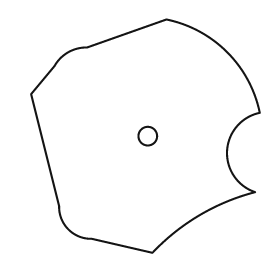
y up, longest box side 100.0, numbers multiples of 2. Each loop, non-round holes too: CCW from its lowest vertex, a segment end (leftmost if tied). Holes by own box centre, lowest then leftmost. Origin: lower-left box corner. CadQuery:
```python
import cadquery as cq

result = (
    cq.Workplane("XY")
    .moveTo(52.0, 0.0)
    .threePointArc((72.0, 16.0), (96.0, 26.0))
    .threePointArc((84.0, 44.0), (98.0, 60.0))
    .threePointArc((84.0, 86.0), (58.0, 100.0))
    .lineTo(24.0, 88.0)
    .threePointArc((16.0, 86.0), (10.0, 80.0))
    .lineTo(0.0, 68.0)
    .lineTo(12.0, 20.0)
    .threePointArc((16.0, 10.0), (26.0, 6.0))
    .close()
    .moveTo(50.0, 50.0)
    .circle(4.0)
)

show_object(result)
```